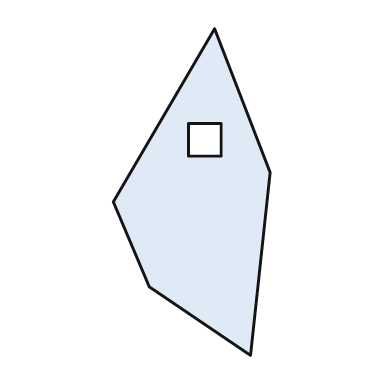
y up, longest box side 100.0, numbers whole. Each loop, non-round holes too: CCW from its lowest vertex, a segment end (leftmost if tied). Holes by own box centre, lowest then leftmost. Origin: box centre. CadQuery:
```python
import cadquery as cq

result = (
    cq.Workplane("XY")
    .moveTo(18.0, -50.0)
    .lineTo(24.0, 6.0)
    .lineTo(7.0, 50.0)
    .lineTo(-24.0, -3.0)
    .lineTo(-13.0, -29.0)
    .close()
    .moveTo(-1.0, 11.0)
    .lineTo(9.0, 11.0)
    .lineTo(9.0, 21.0)
    .lineTo(-1.0, 21.0)
    .close()
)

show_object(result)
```